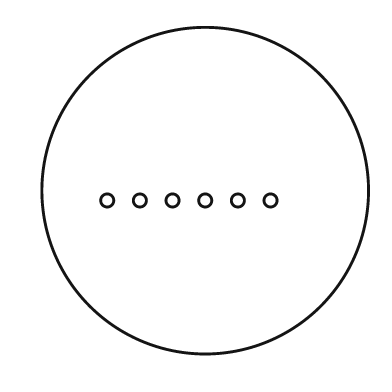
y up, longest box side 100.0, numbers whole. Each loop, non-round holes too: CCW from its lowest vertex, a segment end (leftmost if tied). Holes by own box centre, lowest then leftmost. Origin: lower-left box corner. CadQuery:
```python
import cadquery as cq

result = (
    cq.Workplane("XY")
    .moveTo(50.0, 50.0)
    .circle(50.0)
    .moveTo(20.0, 47.0)
    .circle(2.0)
    .moveTo(30.0, 47.0)
    .circle(2.0)
    .moveTo(40.0, 47.0)
    .circle(2.0)
    .moveTo(50.0, 47.0)
    .circle(2.0)
    .moveTo(60.0, 47.0)
    .circle(2.0)
    .moveTo(70.0, 47.0)
    .circle(2.0)
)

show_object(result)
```